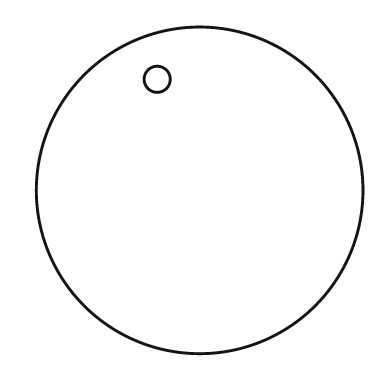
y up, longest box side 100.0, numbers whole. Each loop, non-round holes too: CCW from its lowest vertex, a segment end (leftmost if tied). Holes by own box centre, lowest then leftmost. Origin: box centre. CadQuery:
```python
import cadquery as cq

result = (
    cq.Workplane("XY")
    .moveTo(0.0, 0.0)
    .circle(50.0)
    .moveTo(-13.0, 34.0)
    .circle(4.0)
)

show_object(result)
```